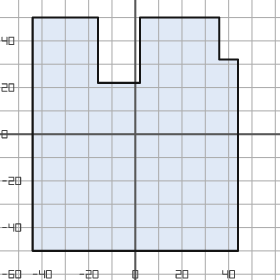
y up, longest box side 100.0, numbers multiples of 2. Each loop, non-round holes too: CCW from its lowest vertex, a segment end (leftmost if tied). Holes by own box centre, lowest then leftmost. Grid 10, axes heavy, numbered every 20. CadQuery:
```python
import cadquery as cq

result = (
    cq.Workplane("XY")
    .moveTo(-44.0, -50.0)
    .lineTo(44.0, -50.0)
    .lineTo(44.0, 32.0)
    .lineTo(36.0, 32.0)
    .lineTo(36.0, 50.0)
    .lineTo(2.0, 50.0)
    .lineTo(2.0, 22.0)
    .lineTo(-16.0, 22.0)
    .lineTo(-16.0, 50.0)
    .lineTo(-44.0, 50.0)
    .close()
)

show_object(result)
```